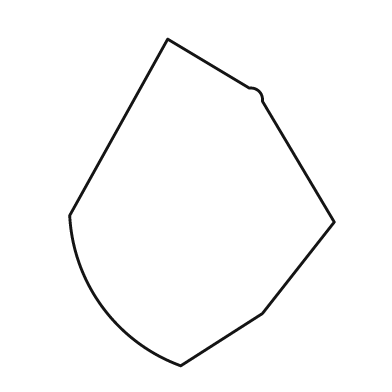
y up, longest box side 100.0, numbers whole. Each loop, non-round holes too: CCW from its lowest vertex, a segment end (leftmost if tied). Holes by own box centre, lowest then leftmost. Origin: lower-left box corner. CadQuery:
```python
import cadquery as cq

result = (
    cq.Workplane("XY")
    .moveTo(34.0, 0.0)
    .lineTo(59.0, 16.0)
    .lineTo(81.0, 44.0)
    .lineTo(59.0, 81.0)
    .threePointArc((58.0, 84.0), (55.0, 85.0))
    .lineTo(30.0, 100.0)
    .lineTo(0.0, 46.0)
    .threePointArc((10.0, 18.0), (34.0, 0.0))
    .close()
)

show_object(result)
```